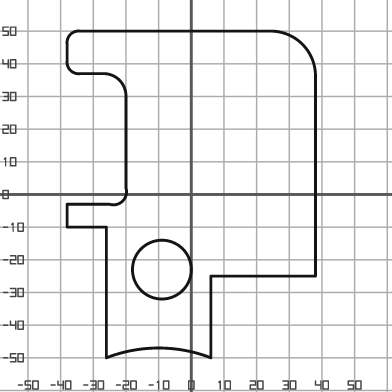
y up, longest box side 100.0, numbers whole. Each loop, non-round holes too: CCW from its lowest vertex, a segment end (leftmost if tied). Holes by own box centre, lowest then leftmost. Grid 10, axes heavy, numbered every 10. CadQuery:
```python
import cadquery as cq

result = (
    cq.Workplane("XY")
    .moveTo(-26.0, -50.0)
    .threePointArc((-10.0, -47.0), (6.0, -50.0))
    .lineTo(6.0, -25.0)
    .lineTo(38.0, -25.0)
    .lineTo(38.0, 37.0)
    .threePointArc((34.0, 46.0), (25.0, 50.0))
    .lineTo(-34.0, 50.0)
    .threePointArc((-37.0, 49.0), (-38.0, 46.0))
    .lineTo(-38.0, 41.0)
    .threePointArc((-37.0, 38.0), (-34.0, 37.0))
    .lineTo(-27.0, 37.0)
    .threePointArc((-22.0, 35.0), (-20.0, 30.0))
    .lineTo(-20.0, 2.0)
    .threePointArc((-21.0, -2.0), (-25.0, -3.0))
    .lineTo(-38.0, -3.0)
    .lineTo(-38.0, -10.0)
    .lineTo(-26.0, -10.0)
    .close()
    .moveTo(-9.0, -23.0)
    .circle(9.0)
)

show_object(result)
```